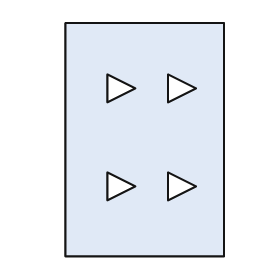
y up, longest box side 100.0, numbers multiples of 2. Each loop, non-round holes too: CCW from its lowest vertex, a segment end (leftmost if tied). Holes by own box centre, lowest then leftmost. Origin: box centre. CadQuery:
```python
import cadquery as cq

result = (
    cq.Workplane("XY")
    .moveTo(-34.0, -50.0)
    .lineTo(34.0, -50.0)
    .lineTo(34.0, 50.0)
    .lineTo(-34.0, 50.0)
    .close()
    .moveTo(-16.0, -26.0)
    .lineTo(-4.0, -20.0)
    .lineTo(-16.0, -14.0)
    .close()
    .moveTo(10.0, -26.0)
    .lineTo(22.0, -20.0)
    .lineTo(10.0, -14.0)
    .close()
    .moveTo(-16.0, 16.0)
    .lineTo(-4.0, 22.0)
    .lineTo(-16.0, 28.0)
    .close()
    .moveTo(10.0, 16.0)
    .lineTo(22.0, 22.0)
    .lineTo(10.0, 28.0)
    .close()
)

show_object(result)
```